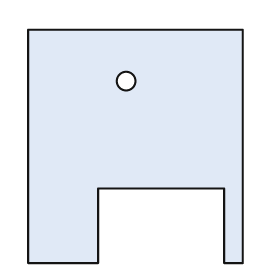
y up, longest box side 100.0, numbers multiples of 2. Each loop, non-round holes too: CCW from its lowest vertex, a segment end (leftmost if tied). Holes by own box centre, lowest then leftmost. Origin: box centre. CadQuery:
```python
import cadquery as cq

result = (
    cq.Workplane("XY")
    .moveTo(-46.0, -50.0)
    .lineTo(-16.0, -50.0)
    .lineTo(-16.0, -18.0)
    .lineTo(38.0, -18.0)
    .lineTo(38.0, -50.0)
    .lineTo(46.0, -50.0)
    .lineTo(46.0, 50.0)
    .lineTo(-46.0, 50.0)
    .close()
    .moveTo(-4.0, 28.0)
    .circle(4.0)
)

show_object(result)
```